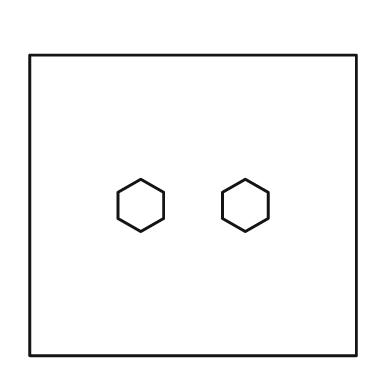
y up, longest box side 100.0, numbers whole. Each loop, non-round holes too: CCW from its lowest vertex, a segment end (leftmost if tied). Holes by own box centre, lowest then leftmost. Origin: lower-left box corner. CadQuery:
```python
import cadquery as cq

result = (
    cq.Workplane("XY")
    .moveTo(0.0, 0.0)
    .lineTo(100.0, 0.0)
    .lineTo(100.0, 92.0)
    .lineTo(0.0, 92.0)
    .close()
    .moveTo(34.0, 38.0)
    .lineTo(41.0, 42.0)
    .lineTo(41.0, 50.0)
    .lineTo(34.0, 54.0)
    .lineTo(27.0, 50.0)
    .lineTo(27.0, 42.0)
    .close()
    .moveTo(66.0, 38.0)
    .lineTo(73.0, 42.0)
    .lineTo(73.0, 50.0)
    .lineTo(66.0, 54.0)
    .lineTo(59.0, 50.0)
    .lineTo(59.0, 42.0)
    .close()
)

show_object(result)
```